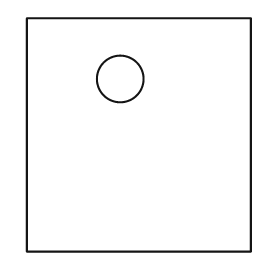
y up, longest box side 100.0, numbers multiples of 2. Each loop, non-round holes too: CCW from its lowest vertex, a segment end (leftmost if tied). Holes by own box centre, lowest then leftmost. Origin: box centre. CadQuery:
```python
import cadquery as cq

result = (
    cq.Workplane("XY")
    .moveTo(-48.0, -50.0)
    .lineTo(48.0, -50.0)
    .lineTo(48.0, 50.0)
    .lineTo(-48.0, 50.0)
    .close()
    .moveTo(-8.0, 24.0)
    .circle(10.0)
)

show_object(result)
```